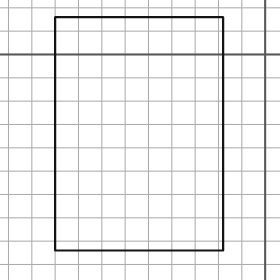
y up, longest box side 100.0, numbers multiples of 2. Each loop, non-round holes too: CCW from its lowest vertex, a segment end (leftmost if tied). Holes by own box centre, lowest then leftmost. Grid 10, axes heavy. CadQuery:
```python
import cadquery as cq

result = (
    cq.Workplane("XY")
    .moveTo(-90.0, -84.0)
    .lineTo(-18.0, -84.0)
    .lineTo(-18.0, 16.0)
    .lineTo(-90.0, 16.0)
    .close()
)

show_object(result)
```